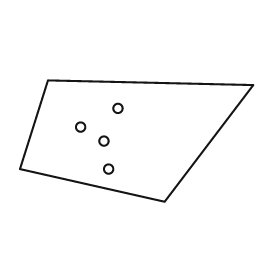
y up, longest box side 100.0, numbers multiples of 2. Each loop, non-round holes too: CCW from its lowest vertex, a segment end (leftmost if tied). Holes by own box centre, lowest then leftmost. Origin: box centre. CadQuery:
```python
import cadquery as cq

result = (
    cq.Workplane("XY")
    .moveTo(12.0, -26.0)
    .lineTo(50.0, 24.0)
    .lineTo(-38.0, 26.0)
    .lineTo(-50.0, -12.0)
    .close()
    .moveTo(-12.0, -12.0)
    .circle(2.0)
    .moveTo(-14.0, 0.0)
    .circle(2.0)
    .moveTo(-24.0, 6.0)
    .circle(2.0)
    .moveTo(-8.0, 14.0)
    .circle(2.0)
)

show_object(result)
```